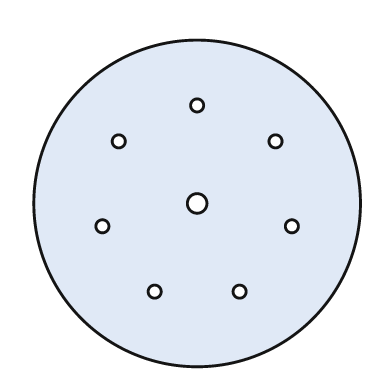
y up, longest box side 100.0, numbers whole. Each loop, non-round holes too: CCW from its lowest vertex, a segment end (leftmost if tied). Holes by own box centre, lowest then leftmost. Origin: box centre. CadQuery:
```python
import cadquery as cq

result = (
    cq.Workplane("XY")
    .moveTo(0.0, 0.0)
    .circle(50.0)
    .moveTo(-13.0, -27.0)
    .circle(2.0)
    .moveTo(13.0, -27.0)
    .circle(2.0)
    .moveTo(-29.0, -7.0)
    .circle(2.0)
    .moveTo(29.0, -7.0)
    .circle(2.0)
    .moveTo(0.0, 0.0)
    .circle(3.0)
    .moveTo(-24.0, 19.0)
    .circle(2.0)
    .moveTo(24.0, 19.0)
    .circle(2.0)
    .moveTo(0.0, 30.0)
    .circle(2.0)
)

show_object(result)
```